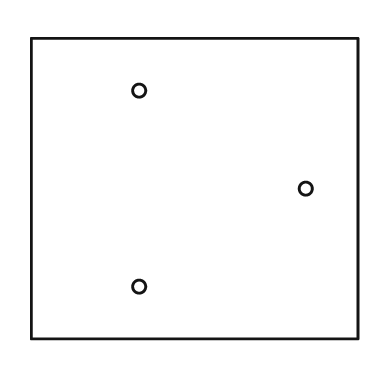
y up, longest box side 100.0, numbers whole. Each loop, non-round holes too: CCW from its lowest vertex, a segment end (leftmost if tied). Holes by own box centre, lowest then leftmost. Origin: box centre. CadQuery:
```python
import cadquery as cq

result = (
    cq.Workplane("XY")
    .moveTo(-50.0, -46.0)
    .lineTo(50.0, -46.0)
    .lineTo(50.0, 46.0)
    .lineTo(-50.0, 46.0)
    .close()
    .moveTo(-17.0, -30.0)
    .circle(2.0)
    .moveTo(34.0, 0.0)
    .circle(2.0)
    .moveTo(-17.0, 30.0)
    .circle(2.0)
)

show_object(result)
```